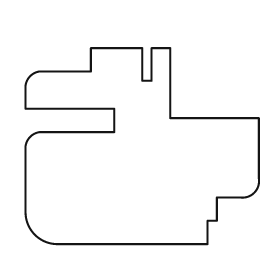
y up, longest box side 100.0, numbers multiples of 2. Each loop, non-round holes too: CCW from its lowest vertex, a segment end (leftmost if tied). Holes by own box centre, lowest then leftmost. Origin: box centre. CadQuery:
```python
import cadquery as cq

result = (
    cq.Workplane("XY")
    .moveTo(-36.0, -42.0)
    .lineTo(28.0, -42.0)
    .lineTo(28.0, -32.0)
    .lineTo(32.0, -32.0)
    .lineTo(32.0, -22.0)
    .lineTo(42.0, -22.0)
    .threePointArc((48.0, -20.0), (50.0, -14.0))
    .lineTo(50.0, 12.0)
    .lineTo(12.0, 12.0)
    .lineTo(12.0, 42.0)
    .lineTo(4.0, 42.0)
    .lineTo(4.0, 28.0)
    .lineTo(0.0, 28.0)
    .lineTo(0.0, 42.0)
    .lineTo(-22.0, 42.0)
    .lineTo(-22.0, 32.0)
    .lineTo(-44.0, 32.0)
    .threePointArc((-48.0, 30.0), (-50.0, 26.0))
    .lineTo(-50.0, 16.0)
    .lineTo(-12.0, 16.0)
    .lineTo(-12.0, 6.0)
    .lineTo(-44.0, 6.0)
    .threePointArc((-48.0, 4.0), (-50.0, 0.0))
    .lineTo(-50.0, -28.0)
    .threePointArc((-46.0, -38.0), (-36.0, -42.0))
    .close()
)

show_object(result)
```